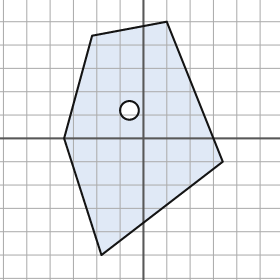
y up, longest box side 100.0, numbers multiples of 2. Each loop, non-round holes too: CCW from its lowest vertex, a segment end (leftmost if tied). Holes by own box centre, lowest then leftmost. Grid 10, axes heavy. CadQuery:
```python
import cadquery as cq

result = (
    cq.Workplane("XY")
    .moveTo(-18.0, -50.0)
    .lineTo(34.0, -10.0)
    .lineTo(10.0, 50.0)
    .lineTo(-22.0, 44.0)
    .lineTo(-34.0, 0.0)
    .close()
    .moveTo(-6.0, 12.0)
    .circle(4.0)
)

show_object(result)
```